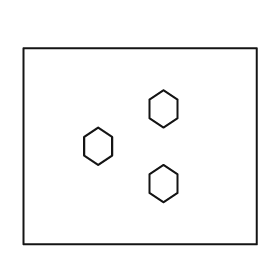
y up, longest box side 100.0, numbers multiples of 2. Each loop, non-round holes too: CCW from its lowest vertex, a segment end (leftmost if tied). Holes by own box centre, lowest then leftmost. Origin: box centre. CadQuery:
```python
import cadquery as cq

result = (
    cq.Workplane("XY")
    .moveTo(-50.0, -42.0)
    .lineTo(50.0, -42.0)
    .lineTo(50.0, 42.0)
    .lineTo(-50.0, 42.0)
    .close()
    .moveTo(10.0, -24.0)
    .lineTo(16.0, -20.0)
    .lineTo(16.0, -12.0)
    .lineTo(10.0, -8.0)
    .lineTo(4.0, -12.0)
    .lineTo(4.0, -20.0)
    .close()
    .moveTo(-18.0, -8.0)
    .lineTo(-12.0, -4.0)
    .lineTo(-12.0, 4.0)
    .lineTo(-18.0, 8.0)
    .lineTo(-24.0, 4.0)
    .lineTo(-24.0, -4.0)
    .close()
    .moveTo(10.0, 8.0)
    .lineTo(16.0, 12.0)
    .lineTo(16.0, 20.0)
    .lineTo(10.0, 24.0)
    .lineTo(4.0, 20.0)
    .lineTo(4.0, 12.0)
    .close()
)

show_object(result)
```